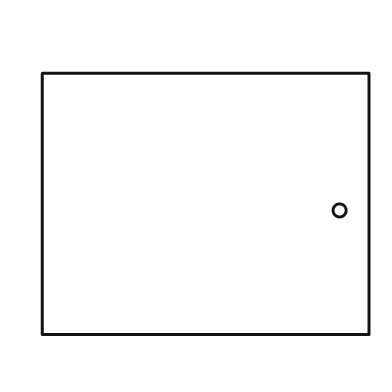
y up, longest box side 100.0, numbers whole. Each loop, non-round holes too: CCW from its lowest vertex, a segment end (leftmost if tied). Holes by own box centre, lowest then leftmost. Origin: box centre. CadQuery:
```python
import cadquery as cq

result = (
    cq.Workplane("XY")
    .moveTo(-50.0, -40.0)
    .lineTo(50.0, -40.0)
    .lineTo(50.0, 40.0)
    .lineTo(-50.0, 40.0)
    .close()
    .moveTo(41.0, -2.0)
    .circle(2.0)
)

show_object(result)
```